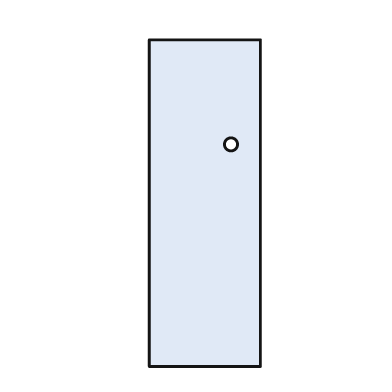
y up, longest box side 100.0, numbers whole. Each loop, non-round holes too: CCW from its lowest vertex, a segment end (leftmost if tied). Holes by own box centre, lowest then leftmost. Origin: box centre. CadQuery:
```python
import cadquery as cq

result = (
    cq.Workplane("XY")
    .moveTo(-17.0, -50.0)
    .lineTo(17.0, -50.0)
    .lineTo(17.0, 50.0)
    .lineTo(-17.0, 50.0)
    .close()
    .moveTo(8.0, 18.0)
    .circle(2.0)
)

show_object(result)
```